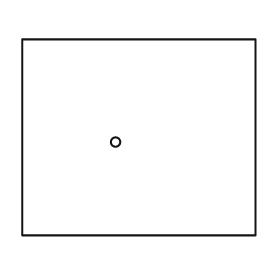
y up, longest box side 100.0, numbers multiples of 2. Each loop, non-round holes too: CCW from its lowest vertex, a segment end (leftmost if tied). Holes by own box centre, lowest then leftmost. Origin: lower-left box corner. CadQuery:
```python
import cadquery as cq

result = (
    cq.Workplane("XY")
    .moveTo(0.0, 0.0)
    .lineTo(100.0, 0.0)
    .lineTo(100.0, 84.0)
    .lineTo(0.0, 84.0)
    .close()
    .moveTo(40.0, 40.0)
    .circle(2.0)
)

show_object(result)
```